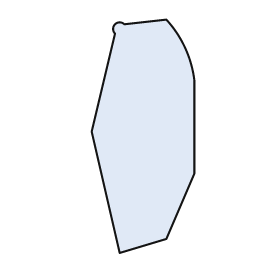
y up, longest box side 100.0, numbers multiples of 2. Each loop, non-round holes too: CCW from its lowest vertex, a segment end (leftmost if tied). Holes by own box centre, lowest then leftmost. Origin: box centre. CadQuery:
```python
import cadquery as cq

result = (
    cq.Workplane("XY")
    .moveTo(-10.0, -50.0)
    .lineTo(10.0, -44.0)
    .lineTo(22.0, -16.0)
    .lineTo(22.0, 24.0)
    .threePointArc((18.0, 38.0), (10.0, 50.0))
    .lineTo(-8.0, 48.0)
    .threePointArc((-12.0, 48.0), (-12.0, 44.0))
    .lineTo(-22.0, 2.0)
    .close()
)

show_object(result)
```